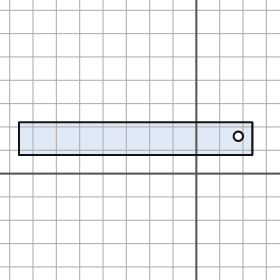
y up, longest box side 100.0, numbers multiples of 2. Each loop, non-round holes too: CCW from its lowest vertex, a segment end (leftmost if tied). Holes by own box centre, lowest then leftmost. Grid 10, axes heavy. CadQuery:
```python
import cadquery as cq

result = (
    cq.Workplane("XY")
    .moveTo(-76.0, 8.0)
    .lineTo(24.0, 8.0)
    .lineTo(24.0, 22.0)
    .lineTo(-76.0, 22.0)
    .close()
    .moveTo(18.0, 16.0)
    .circle(2.0)
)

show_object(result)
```